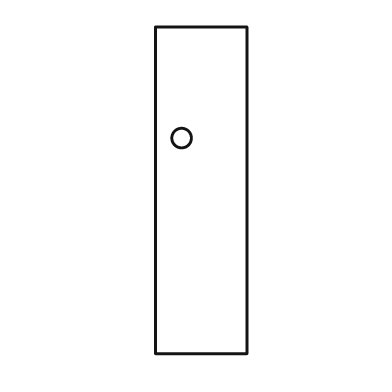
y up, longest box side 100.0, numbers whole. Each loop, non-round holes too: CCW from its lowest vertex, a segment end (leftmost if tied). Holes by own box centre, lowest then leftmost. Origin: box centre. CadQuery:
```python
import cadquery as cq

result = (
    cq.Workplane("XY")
    .moveTo(-14.0, -50.0)
    .lineTo(14.0, -50.0)
    .lineTo(14.0, 50.0)
    .lineTo(-14.0, 50.0)
    .close()
    .moveTo(-6.0, 16.0)
    .circle(3.0)
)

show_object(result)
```